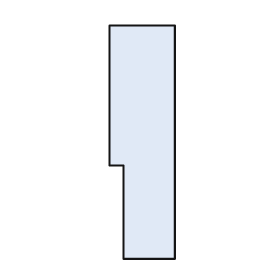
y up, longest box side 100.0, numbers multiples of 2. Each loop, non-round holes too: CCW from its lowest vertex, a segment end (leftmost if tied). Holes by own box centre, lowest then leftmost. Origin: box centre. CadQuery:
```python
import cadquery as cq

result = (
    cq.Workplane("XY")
    .moveTo(-8.0, -50.0)
    .lineTo(14.0, -50.0)
    .lineTo(14.0, 50.0)
    .lineTo(-14.0, 50.0)
    .lineTo(-14.0, -10.0)
    .lineTo(-8.0, -10.0)
    .close()
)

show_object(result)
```